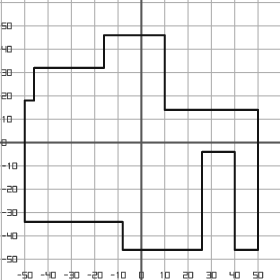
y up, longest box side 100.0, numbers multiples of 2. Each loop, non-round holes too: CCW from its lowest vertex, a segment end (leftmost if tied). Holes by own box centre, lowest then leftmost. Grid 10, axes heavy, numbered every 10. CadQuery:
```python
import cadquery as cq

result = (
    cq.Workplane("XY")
    .moveTo(-8.0, -46.0)
    .lineTo(26.0, -46.0)
    .lineTo(26.0, -4.0)
    .lineTo(40.0, -4.0)
    .lineTo(40.0, -46.0)
    .lineTo(50.0, -46.0)
    .lineTo(50.0, 14.0)
    .lineTo(10.0, 14.0)
    .lineTo(10.0, 46.0)
    .lineTo(-16.0, 46.0)
    .lineTo(-16.0, 32.0)
    .lineTo(-46.0, 32.0)
    .lineTo(-46.0, 18.0)
    .lineTo(-50.0, 18.0)
    .lineTo(-50.0, -34.0)
    .lineTo(-8.0, -34.0)
    .close()
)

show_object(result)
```